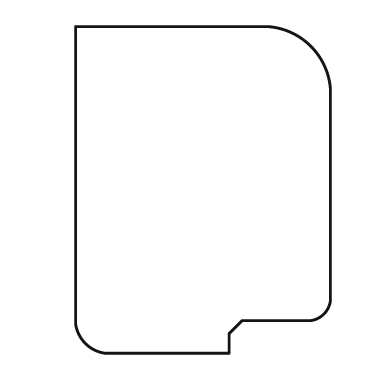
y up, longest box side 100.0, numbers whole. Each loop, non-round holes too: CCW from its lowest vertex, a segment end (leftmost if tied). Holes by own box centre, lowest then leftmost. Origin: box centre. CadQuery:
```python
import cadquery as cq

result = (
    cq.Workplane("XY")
    .moveTo(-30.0, -50.0)
    .lineTo(8.0, -50.0)
    .lineTo(8.0, -44.0)
    .lineTo(12.0, -40.0)
    .lineTo(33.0, -40.0)
    .threePointArc((37.0, -38.0), (39.0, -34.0))
    .lineTo(39.0, 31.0)
    .threePointArc((33.0, 44.0), (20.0, 50.0))
    .lineTo(-39.0, 50.0)
    .lineTo(-39.0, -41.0)
    .threePointArc((-36.0, -47.0), (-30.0, -50.0))
    .close()
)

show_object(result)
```